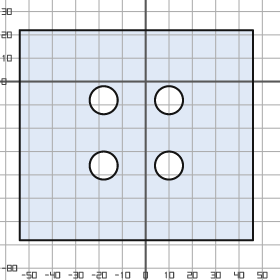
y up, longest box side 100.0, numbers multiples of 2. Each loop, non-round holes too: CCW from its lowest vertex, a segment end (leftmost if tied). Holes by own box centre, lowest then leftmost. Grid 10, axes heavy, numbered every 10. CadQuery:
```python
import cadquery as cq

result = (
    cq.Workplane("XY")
    .moveTo(-54.0, -68.0)
    .lineTo(46.0, -68.0)
    .lineTo(46.0, 22.0)
    .lineTo(-54.0, 22.0)
    .close()
    .moveTo(-18.0, -36.0)
    .circle(6.0)
    .moveTo(10.0, -36.0)
    .circle(6.0)
    .moveTo(-18.0, -8.0)
    .circle(6.0)
    .moveTo(10.0, -8.0)
    .circle(6.0)
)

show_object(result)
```